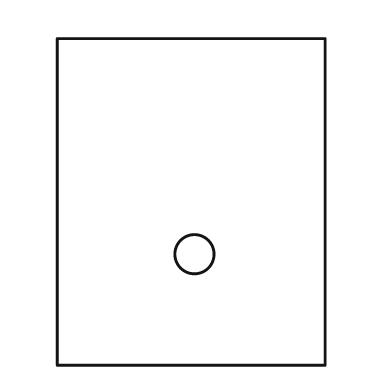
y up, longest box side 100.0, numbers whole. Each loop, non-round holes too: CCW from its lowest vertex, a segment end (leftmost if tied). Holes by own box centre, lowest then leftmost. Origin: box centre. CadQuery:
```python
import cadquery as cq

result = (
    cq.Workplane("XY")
    .moveTo(-41.0, -50.0)
    .lineTo(41.0, -50.0)
    .lineTo(41.0, 50.0)
    .lineTo(-41.0, 50.0)
    .close()
    .moveTo(1.0, -16.0)
    .circle(6.0)
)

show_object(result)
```